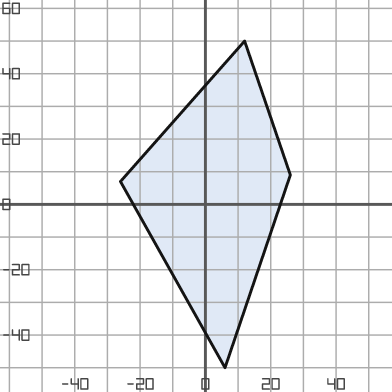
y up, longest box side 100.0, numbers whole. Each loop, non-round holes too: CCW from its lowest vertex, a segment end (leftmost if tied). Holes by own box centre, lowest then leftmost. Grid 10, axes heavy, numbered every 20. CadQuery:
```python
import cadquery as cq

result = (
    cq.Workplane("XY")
    .moveTo(6.0, -50.0)
    .lineTo(26.0, 9.0)
    .lineTo(12.0, 50.0)
    .lineTo(-26.0, 7.0)
    .close()
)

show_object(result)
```